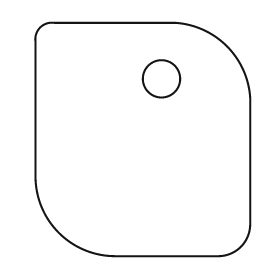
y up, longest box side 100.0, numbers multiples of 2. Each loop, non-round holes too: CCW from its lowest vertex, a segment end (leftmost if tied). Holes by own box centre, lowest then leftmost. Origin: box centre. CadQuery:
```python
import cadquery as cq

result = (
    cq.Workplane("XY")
    .moveTo(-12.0, -50.0)
    .lineTo(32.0, -50.0)
    .threePointArc((42.0, -46.0), (46.0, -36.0))
    .lineTo(46.0, 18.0)
    .threePointArc((36.0, 40.0), (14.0, 50.0))
    .lineTo(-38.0, 50.0)
    .threePointArc((-44.0, 48.0), (-46.0, 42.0))
    .lineTo(-46.0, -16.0)
    .threePointArc((-36.0, -40.0), (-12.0, -50.0))
    .close()
    .moveTo(8.0, 26.0)
    .circle(8.0)
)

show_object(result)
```